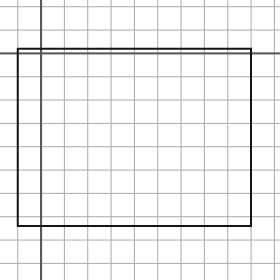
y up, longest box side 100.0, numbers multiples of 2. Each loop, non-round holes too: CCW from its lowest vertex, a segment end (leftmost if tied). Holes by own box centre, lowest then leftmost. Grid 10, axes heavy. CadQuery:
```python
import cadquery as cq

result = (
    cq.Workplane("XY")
    .moveTo(-10.0, -74.0)
    .lineTo(90.0, -74.0)
    .lineTo(90.0, 2.0)
    .lineTo(-10.0, 2.0)
    .close()
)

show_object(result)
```